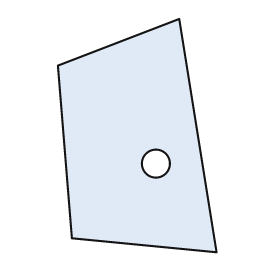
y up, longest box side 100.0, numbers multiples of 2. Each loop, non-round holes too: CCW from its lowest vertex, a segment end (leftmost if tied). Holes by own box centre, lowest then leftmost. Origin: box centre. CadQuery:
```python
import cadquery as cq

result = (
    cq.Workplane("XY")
    .moveTo(34.0, -50.0)
    .lineTo(18.0, 50.0)
    .lineTo(-34.0, 30.0)
    .lineTo(-28.0, -44.0)
    .close()
    .moveTo(8.0, -12.0)
    .circle(6.0)
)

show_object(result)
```